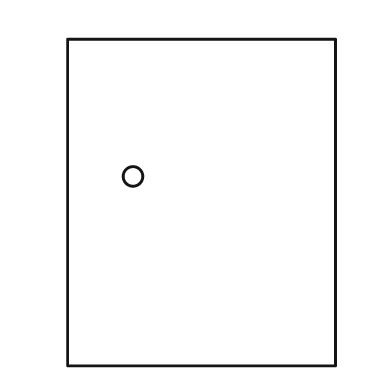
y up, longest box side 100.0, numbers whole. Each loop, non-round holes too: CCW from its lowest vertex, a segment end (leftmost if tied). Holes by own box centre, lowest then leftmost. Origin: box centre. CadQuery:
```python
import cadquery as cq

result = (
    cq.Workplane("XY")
    .moveTo(-41.0, -50.0)
    .lineTo(41.0, -50.0)
    .lineTo(41.0, 50.0)
    .lineTo(-41.0, 50.0)
    .close()
    .moveTo(-21.0, 8.0)
    .circle(3.0)
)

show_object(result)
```